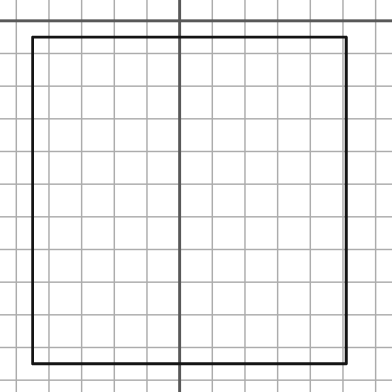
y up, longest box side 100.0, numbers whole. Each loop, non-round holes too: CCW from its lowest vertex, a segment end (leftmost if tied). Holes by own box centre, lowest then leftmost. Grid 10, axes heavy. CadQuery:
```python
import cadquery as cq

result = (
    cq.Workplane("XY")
    .moveTo(-45.0, -105.0)
    .lineTo(51.0, -105.0)
    .lineTo(51.0, -5.0)
    .lineTo(-45.0, -5.0)
    .close()
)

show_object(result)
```